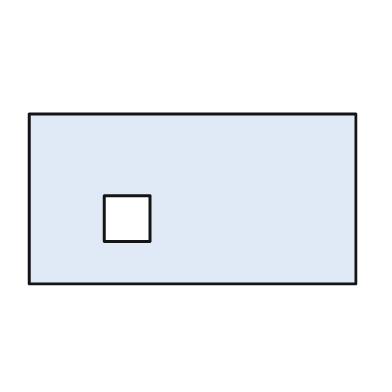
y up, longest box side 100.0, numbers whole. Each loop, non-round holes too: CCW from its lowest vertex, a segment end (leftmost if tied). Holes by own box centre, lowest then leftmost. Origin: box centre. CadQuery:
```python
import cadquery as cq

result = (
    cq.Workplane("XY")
    .moveTo(-50.0, -26.0)
    .lineTo(50.0, -26.0)
    .lineTo(50.0, 26.0)
    .lineTo(-50.0, 26.0)
    .close()
    .moveTo(-27.0, -13.0)
    .lineTo(-13.0, -13.0)
    .lineTo(-13.0, 1.0)
    .lineTo(-27.0, 1.0)
    .close()
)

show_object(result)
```